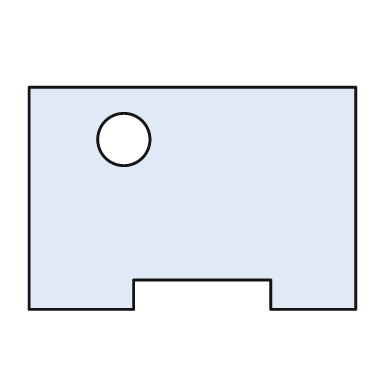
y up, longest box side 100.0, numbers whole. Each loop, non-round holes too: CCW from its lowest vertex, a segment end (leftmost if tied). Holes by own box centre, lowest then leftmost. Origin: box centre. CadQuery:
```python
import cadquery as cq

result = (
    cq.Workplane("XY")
    .moveTo(-50.0, -34.0)
    .lineTo(-18.0, -34.0)
    .lineTo(-18.0, -25.0)
    .lineTo(24.0, -25.0)
    .lineTo(24.0, -34.0)
    .lineTo(50.0, -34.0)
    .lineTo(50.0, 34.0)
    .lineTo(-50.0, 34.0)
    .close()
    .moveTo(-21.0, 18.0)
    .circle(8.0)
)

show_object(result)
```